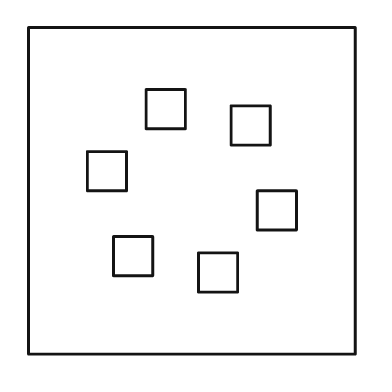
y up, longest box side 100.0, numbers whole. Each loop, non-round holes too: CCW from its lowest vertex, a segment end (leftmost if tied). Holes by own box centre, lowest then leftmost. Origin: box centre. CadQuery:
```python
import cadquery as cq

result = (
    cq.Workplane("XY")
    .moveTo(-50.0, -50.0)
    .lineTo(50.0, -50.0)
    .lineTo(50.0, 50.0)
    .lineTo(-50.0, 50.0)
    .close()
    .moveTo(2.0, -31.0)
    .lineTo(14.0, -31.0)
    .lineTo(14.0, -19.0)
    .lineTo(2.0, -19.0)
    .close()
    .moveTo(-24.0, -26.0)
    .lineTo(-12.0, -26.0)
    .lineTo(-12.0, -14.0)
    .lineTo(-24.0, -14.0)
    .close()
    .moveTo(20.0, -12.0)
    .lineTo(32.0, -12.0)
    .lineTo(32.0, 0.0)
    .lineTo(20.0, 0.0)
    .close()
    .moveTo(-32.0, 0.0)
    .lineTo(-20.0, 0.0)
    .lineTo(-20.0, 12.0)
    .lineTo(-32.0, 12.0)
    .close()
    .moveTo(12.0, 14.0)
    .lineTo(24.0, 14.0)
    .lineTo(24.0, 26.0)
    .lineTo(12.0, 26.0)
    .close()
    .moveTo(-14.0, 19.0)
    .lineTo(-2.0, 19.0)
    .lineTo(-2.0, 31.0)
    .lineTo(-14.0, 31.0)
    .close()
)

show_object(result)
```